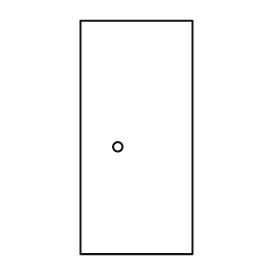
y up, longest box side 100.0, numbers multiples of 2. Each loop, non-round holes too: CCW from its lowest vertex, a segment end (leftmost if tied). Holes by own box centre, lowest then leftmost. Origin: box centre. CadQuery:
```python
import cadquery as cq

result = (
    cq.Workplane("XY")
    .moveTo(-24.0, -50.0)
    .lineTo(24.0, -50.0)
    .lineTo(24.0, 50.0)
    .lineTo(-24.0, 50.0)
    .close()
    .moveTo(-8.0, -4.0)
    .circle(2.0)
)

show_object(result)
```